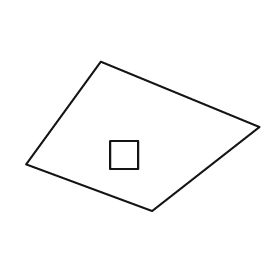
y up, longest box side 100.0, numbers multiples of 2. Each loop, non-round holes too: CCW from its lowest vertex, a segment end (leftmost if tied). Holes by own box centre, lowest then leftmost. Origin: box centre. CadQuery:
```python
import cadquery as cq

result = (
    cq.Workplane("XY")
    .moveTo(4.0, -32.0)
    .lineTo(50.0, 4.0)
    .lineTo(-18.0, 32.0)
    .lineTo(-50.0, -12.0)
    .close()
    .moveTo(-14.0, -14.0)
    .lineTo(-2.0, -14.0)
    .lineTo(-2.0, -2.0)
    .lineTo(-14.0, -2.0)
    .close()
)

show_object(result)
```